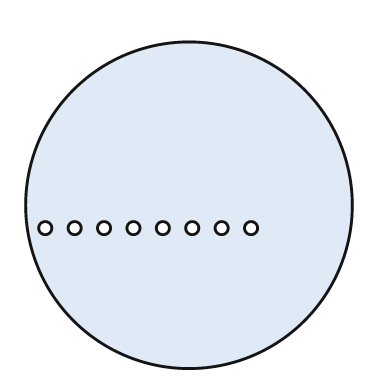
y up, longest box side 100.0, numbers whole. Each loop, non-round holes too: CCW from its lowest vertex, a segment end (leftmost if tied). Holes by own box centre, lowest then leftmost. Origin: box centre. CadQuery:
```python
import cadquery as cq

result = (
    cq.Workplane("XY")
    .moveTo(0.0, 0.0)
    .circle(50.0)
    .moveTo(-44.0, -7.0)
    .circle(2.0)
    .moveTo(-35.0, -7.0)
    .circle(2.0)
    .moveTo(-26.0, -7.0)
    .circle(2.0)
    .moveTo(-17.0, -7.0)
    .circle(2.0)
    .moveTo(-8.0, -7.0)
    .circle(2.0)
    .moveTo(1.0, -7.0)
    .circle(2.0)
    .moveTo(10.0, -7.0)
    .circle(2.0)
    .moveTo(19.0, -7.0)
    .circle(2.0)
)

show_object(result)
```